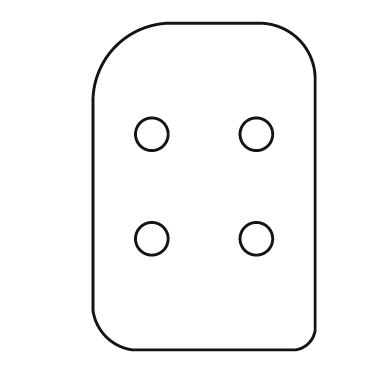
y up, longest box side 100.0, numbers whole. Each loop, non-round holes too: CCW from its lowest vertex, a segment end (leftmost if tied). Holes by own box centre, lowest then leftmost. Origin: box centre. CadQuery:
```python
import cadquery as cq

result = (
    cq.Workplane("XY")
    .moveTo(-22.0, -50.0)
    .lineTo(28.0, -50.0)
    .threePointArc((32.0, -48.0), (34.0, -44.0))
    .lineTo(34.0, 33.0)
    .threePointArc((29.0, 45.0), (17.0, 50.0))
    .lineTo(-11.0, 50.0)
    .threePointArc((-27.0, 43.0), (-34.0, 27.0))
    .lineTo(-34.0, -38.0)
    .threePointArc((-30.0, -46.0), (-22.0, -50.0))
    .close()
    .moveTo(-16.0, -16.0)
    .circle(5.0)
    .moveTo(16.0, -16.0)
    .circle(5.0)
    .moveTo(-16.0, 16.0)
    .circle(5.0)
    .moveTo(16.0, 16.0)
    .circle(5.0)
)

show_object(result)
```